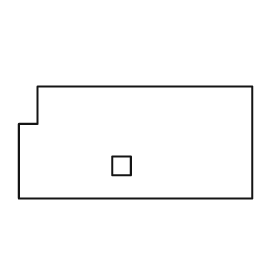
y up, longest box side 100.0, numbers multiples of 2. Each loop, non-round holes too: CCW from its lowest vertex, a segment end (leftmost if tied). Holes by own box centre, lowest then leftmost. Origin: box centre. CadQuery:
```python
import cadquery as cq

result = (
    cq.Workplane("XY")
    .moveTo(-50.0, -24.0)
    .lineTo(50.0, -24.0)
    .lineTo(50.0, 24.0)
    .lineTo(-42.0, 24.0)
    .lineTo(-42.0, 8.0)
    .lineTo(-50.0, 8.0)
    .close()
    .moveTo(-10.0, -14.0)
    .lineTo(-2.0, -14.0)
    .lineTo(-2.0, -6.0)
    .lineTo(-10.0, -6.0)
    .close()
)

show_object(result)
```